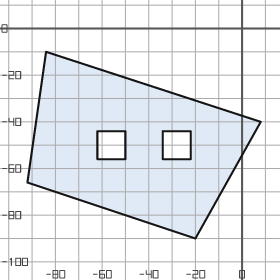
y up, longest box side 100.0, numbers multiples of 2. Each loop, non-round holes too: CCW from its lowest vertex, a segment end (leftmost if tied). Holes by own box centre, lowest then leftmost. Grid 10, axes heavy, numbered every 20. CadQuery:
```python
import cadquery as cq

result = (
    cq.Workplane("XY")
    .moveTo(-20.0, -90.0)
    .lineTo(8.0, -40.0)
    .lineTo(-84.0, -10.0)
    .lineTo(-92.0, -66.0)
    .close()
    .moveTo(-62.0, -56.0)
    .lineTo(-50.0, -56.0)
    .lineTo(-50.0, -44.0)
    .lineTo(-62.0, -44.0)
    .close()
    .moveTo(-34.0, -56.0)
    .lineTo(-22.0, -56.0)
    .lineTo(-22.0, -44.0)
    .lineTo(-34.0, -44.0)
    .close()
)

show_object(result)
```